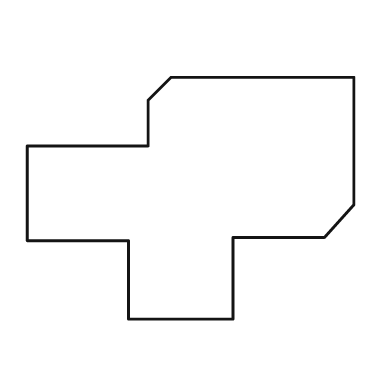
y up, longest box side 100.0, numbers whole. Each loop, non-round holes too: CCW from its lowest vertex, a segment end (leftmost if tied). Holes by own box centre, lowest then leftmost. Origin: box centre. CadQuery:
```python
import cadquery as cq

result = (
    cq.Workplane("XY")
    .moveTo(-19.0, -37.0)
    .lineTo(13.0, -37.0)
    .lineTo(13.0, -12.0)
    .lineTo(41.0, -12.0)
    .lineTo(50.0, -2.0)
    .lineTo(50.0, 37.0)
    .lineTo(-6.0, 37.0)
    .lineTo(-13.0, 30.0)
    .lineTo(-13.0, 16.0)
    .lineTo(-50.0, 16.0)
    .lineTo(-50.0, -13.0)
    .lineTo(-19.0, -13.0)
    .close()
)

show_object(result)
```